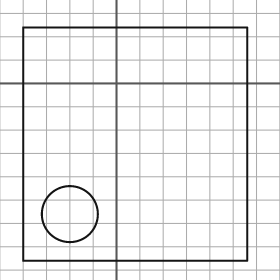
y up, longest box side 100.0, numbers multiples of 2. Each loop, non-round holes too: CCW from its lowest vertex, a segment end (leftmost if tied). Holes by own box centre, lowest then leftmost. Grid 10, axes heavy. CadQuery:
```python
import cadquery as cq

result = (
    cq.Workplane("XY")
    .moveTo(-40.0, -76.0)
    .lineTo(56.0, -76.0)
    .lineTo(56.0, 24.0)
    .lineTo(-40.0, 24.0)
    .close()
    .moveTo(-20.0, -56.0)
    .circle(12.0)
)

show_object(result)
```